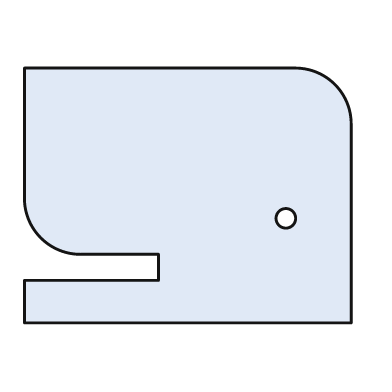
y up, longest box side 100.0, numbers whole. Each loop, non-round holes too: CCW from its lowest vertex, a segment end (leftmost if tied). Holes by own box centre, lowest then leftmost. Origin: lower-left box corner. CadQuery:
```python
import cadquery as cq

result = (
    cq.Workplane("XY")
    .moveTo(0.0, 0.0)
    .lineTo(100.0, 0.0)
    .lineTo(100.0, 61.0)
    .threePointArc((95.0, 73.0), (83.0, 78.0))
    .lineTo(0.0, 78.0)
    .lineTo(0.0, 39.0)
    .threePointArc((5.0, 26.0), (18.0, 21.0))
    .lineTo(41.0, 21.0)
    .lineTo(41.0, 13.0)
    .lineTo(0.0, 13.0)
    .close()
    .moveTo(80.0, 32.0)
    .circle(3.0)
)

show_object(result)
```